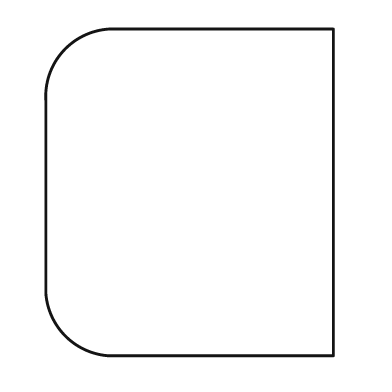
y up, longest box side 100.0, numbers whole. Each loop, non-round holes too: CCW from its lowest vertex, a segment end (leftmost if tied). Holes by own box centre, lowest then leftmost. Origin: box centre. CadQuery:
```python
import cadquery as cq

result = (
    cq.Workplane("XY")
    .moveTo(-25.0, -50.0)
    .lineTo(44.0, -50.0)
    .lineTo(44.0, 50.0)
    .lineTo(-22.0, 50.0)
    .threePointArc((-38.0, 44.0), (-44.0, 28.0))
    .lineTo(-44.0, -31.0)
    .threePointArc((-38.0, -44.0), (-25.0, -50.0))
    .close()
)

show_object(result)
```